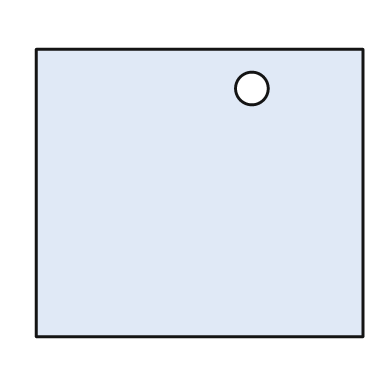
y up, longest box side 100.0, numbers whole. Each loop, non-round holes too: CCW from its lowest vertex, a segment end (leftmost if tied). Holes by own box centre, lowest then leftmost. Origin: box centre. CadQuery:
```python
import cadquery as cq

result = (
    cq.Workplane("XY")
    .moveTo(-50.0, -44.0)
    .lineTo(50.0, -44.0)
    .lineTo(50.0, 44.0)
    .lineTo(-50.0, 44.0)
    .close()
    .moveTo(16.0, 32.0)
    .circle(5.0)
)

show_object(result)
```